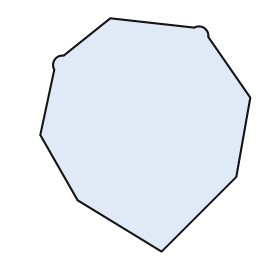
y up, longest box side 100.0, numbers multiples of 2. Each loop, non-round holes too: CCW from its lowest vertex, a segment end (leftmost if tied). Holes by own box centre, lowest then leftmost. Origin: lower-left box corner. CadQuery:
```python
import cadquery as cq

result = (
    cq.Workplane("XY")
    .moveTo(52.0, 0.0)
    .lineTo(84.0, 32.0)
    .lineTo(90.0, 66.0)
    .lineTo(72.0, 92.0)
    .threePointArc((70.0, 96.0), (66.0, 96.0))
    .lineTo(30.0, 100.0)
    .lineTo(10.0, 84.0)
    .threePointArc((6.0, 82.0), (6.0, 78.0))
    .lineTo(0.0, 50.0)
    .lineTo(16.0, 22.0)
    .close()
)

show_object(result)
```